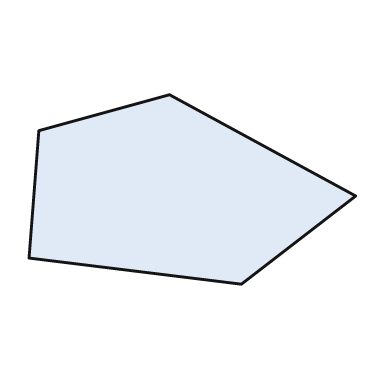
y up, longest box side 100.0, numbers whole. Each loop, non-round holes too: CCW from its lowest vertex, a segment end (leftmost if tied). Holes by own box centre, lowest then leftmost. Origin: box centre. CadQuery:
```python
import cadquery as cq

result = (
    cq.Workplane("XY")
    .moveTo(15.0, -29.0)
    .lineTo(50.0, -2.0)
    .lineTo(-7.0, 29.0)
    .lineTo(-47.0, 18.0)
    .lineTo(-50.0, -21.0)
    .close()
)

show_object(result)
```